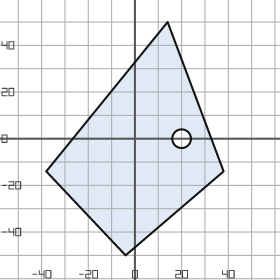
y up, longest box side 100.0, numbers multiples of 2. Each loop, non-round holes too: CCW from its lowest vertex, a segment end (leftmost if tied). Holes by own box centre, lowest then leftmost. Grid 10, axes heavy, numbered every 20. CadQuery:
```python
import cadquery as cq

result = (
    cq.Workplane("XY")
    .moveTo(-4.0, -50.0)
    .lineTo(38.0, -14.0)
    .lineTo(14.0, 50.0)
    .lineTo(-38.0, -14.0)
    .close()
    .moveTo(20.0, 0.0)
    .circle(4.0)
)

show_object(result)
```